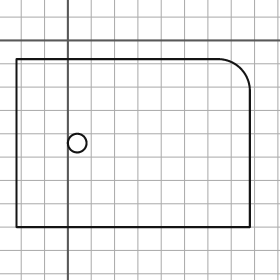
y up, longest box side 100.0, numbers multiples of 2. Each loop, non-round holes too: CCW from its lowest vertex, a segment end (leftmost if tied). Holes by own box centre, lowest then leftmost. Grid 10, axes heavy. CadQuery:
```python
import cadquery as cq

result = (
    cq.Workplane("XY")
    .moveTo(-22.0, -80.0)
    .lineTo(78.0, -80.0)
    .lineTo(78.0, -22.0)
    .threePointArc((74.0, -12.0), (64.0, -8.0))
    .lineTo(-22.0, -8.0)
    .close()
    .moveTo(4.0, -44.0)
    .circle(4.0)
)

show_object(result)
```